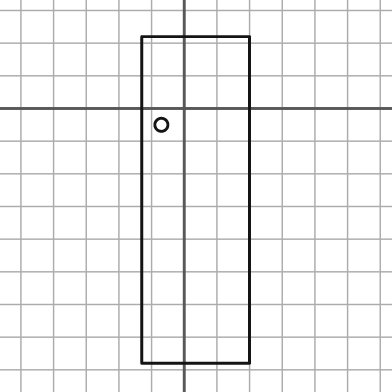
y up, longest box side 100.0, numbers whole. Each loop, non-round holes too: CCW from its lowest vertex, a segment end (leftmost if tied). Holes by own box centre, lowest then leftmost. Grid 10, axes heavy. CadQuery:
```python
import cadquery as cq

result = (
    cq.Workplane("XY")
    .moveTo(-13.0, -78.0)
    .lineTo(20.0, -78.0)
    .lineTo(20.0, 22.0)
    .lineTo(-13.0, 22.0)
    .close()
    .moveTo(-7.0, -5.0)
    .circle(2.0)
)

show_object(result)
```